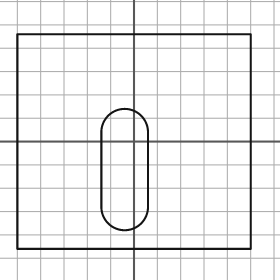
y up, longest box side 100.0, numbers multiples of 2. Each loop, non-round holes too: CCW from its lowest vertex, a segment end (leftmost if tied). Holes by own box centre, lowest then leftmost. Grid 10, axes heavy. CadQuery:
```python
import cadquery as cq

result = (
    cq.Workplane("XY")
    .moveTo(-50.0, -46.0)
    .lineTo(50.0, -46.0)
    .lineTo(50.0, 46.0)
    .lineTo(-50.0, 46.0)
    .close()
    .moveTo(-14.0, -28.0)
    .threePointArc((-4.0, -38.0), (6.0, -28.0))
    .lineTo(6.0, 4.0)
    .threePointArc((-4.0, 14.0), (-14.0, 4.0))
    .close()
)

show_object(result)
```